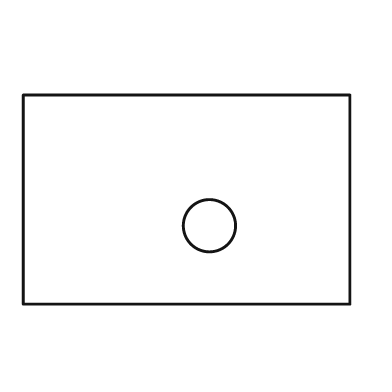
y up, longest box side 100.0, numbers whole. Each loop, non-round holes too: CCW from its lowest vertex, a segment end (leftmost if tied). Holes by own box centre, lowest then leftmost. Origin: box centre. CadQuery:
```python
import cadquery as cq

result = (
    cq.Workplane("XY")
    .moveTo(-50.0, -32.0)
    .lineTo(50.0, -32.0)
    .lineTo(50.0, 32.0)
    .lineTo(-50.0, 32.0)
    .close()
    .moveTo(7.0, -8.0)
    .circle(8.0)
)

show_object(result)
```